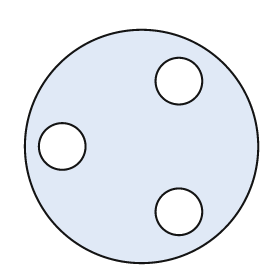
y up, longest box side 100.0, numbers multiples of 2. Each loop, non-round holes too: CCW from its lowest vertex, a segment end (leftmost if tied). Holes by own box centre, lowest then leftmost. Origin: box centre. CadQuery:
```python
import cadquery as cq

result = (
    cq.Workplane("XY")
    .moveTo(0.0, 0.0)
    .circle(50.0)
    .moveTo(16.0, -28.0)
    .circle(10.0)
    .moveTo(-34.0, 0.0)
    .circle(10.0)
    .moveTo(16.0, 28.0)
    .circle(10.0)
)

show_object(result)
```